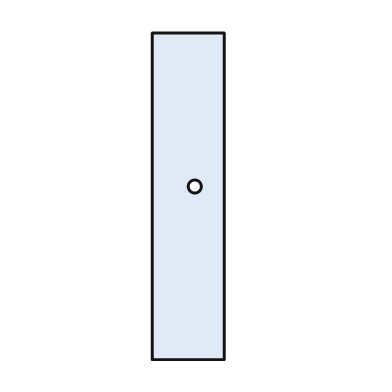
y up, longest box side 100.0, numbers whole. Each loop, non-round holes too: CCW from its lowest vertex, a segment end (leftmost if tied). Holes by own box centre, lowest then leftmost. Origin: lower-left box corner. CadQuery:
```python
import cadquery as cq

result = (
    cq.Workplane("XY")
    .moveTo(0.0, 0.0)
    .lineTo(22.0, 0.0)
    .lineTo(22.0, 100.0)
    .lineTo(0.0, 100.0)
    .close()
    .moveTo(13.0, 53.0)
    .circle(2.0)
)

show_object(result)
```